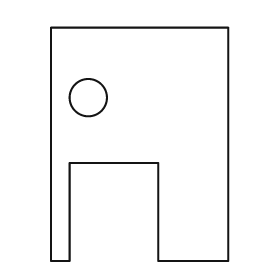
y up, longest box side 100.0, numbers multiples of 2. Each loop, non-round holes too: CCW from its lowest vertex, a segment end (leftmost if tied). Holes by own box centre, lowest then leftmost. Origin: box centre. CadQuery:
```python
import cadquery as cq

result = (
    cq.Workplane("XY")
    .moveTo(-38.0, -50.0)
    .lineTo(-30.0, -50.0)
    .lineTo(-30.0, -8.0)
    .lineTo(8.0, -8.0)
    .lineTo(8.0, -50.0)
    .lineTo(38.0, -50.0)
    .lineTo(38.0, 50.0)
    .lineTo(-38.0, 50.0)
    .close()
    .moveTo(-22.0, 20.0)
    .circle(8.0)
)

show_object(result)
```